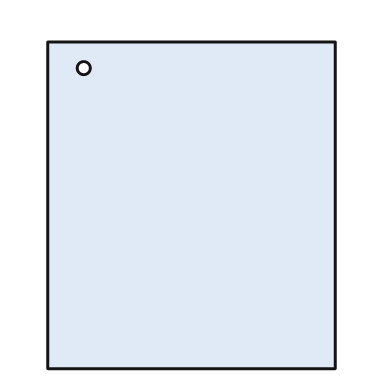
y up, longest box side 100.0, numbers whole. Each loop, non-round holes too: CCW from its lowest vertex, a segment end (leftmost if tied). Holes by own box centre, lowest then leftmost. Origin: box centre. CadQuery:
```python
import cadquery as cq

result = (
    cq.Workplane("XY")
    .moveTo(-44.0, -50.0)
    .lineTo(44.0, -50.0)
    .lineTo(44.0, 50.0)
    .lineTo(-44.0, 50.0)
    .close()
    .moveTo(-33.0, 42.0)
    .circle(2.0)
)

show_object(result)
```